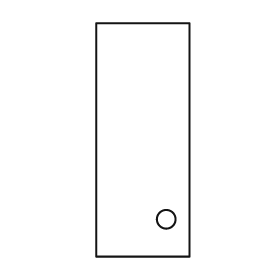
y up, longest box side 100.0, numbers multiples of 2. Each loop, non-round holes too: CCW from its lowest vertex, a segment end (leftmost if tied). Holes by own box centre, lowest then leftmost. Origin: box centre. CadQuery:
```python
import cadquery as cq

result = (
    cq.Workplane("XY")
    .moveTo(-20.0, -50.0)
    .lineTo(20.0, -50.0)
    .lineTo(20.0, 50.0)
    .lineTo(-20.0, 50.0)
    .close()
    .moveTo(10.0, -34.0)
    .circle(4.0)
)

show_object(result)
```